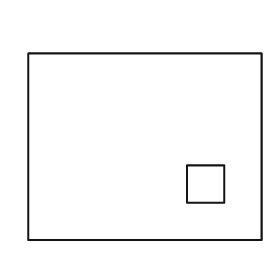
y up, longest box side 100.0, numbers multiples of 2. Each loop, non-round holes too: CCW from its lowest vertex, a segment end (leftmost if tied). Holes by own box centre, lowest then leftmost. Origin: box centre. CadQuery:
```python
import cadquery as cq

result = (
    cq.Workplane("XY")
    .moveTo(-50.0, -40.0)
    .lineTo(50.0, -40.0)
    .lineTo(50.0, 40.0)
    .lineTo(-50.0, 40.0)
    .close()
    .moveTo(18.0, -24.0)
    .lineTo(34.0, -24.0)
    .lineTo(34.0, -8.0)
    .lineTo(18.0, -8.0)
    .close()
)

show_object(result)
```